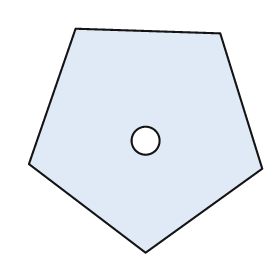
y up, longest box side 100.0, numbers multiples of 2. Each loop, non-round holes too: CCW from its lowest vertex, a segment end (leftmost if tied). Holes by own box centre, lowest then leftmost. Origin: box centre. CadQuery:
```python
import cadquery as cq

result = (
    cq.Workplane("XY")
    .moveTo(0.0, -48.0)
    .lineTo(50.0, -12.0)
    .lineTo(32.0, 46.0)
    .lineTo(-30.0, 48.0)
    .lineTo(-50.0, -10.0)
    .close()
    .moveTo(0.0, 0.0)
    .circle(6.0)
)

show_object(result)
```